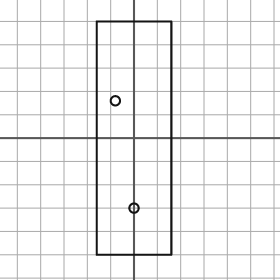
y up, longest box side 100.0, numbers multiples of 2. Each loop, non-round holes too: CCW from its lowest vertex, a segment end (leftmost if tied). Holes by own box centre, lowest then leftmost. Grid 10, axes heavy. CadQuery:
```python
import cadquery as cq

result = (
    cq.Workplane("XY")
    .moveTo(-16.0, -50.0)
    .lineTo(16.0, -50.0)
    .lineTo(16.0, 50.0)
    .lineTo(-16.0, 50.0)
    .close()
    .moveTo(0.0, -30.0)
    .circle(2.0)
    .moveTo(-8.0, 16.0)
    .circle(2.0)
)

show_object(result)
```